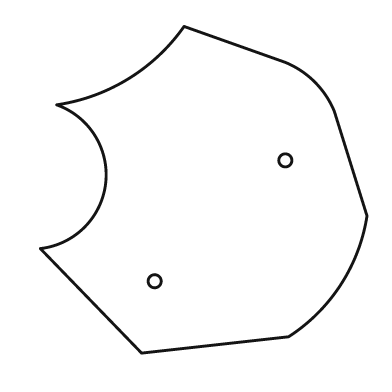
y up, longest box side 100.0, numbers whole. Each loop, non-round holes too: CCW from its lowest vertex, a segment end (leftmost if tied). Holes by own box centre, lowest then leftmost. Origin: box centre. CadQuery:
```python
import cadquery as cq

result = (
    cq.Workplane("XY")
    .moveTo(-19.0, -50.0)
    .lineTo(26.0, -45.0)
    .threePointArc((42.0, -29.0), (50.0, -8.0))
    .lineTo(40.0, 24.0)
    .threePointArc((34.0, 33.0), (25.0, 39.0))
    .lineTo(-6.0, 50.0)
    .threePointArc((-23.0, 34.0), (-45.0, 26.0))
    .threePointArc((-30.0, 2.0), (-50.0, -18.0))
    .close()
    .moveTo(-15.0, -28.0)
    .circle(2.0)
    .moveTo(25.0, 9.0)
    .circle(2.0)
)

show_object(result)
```